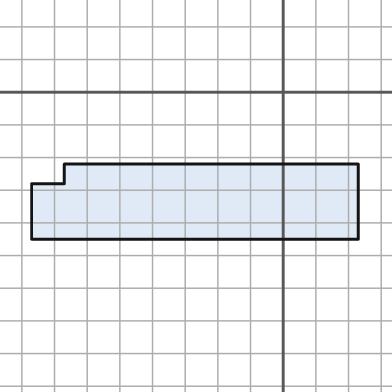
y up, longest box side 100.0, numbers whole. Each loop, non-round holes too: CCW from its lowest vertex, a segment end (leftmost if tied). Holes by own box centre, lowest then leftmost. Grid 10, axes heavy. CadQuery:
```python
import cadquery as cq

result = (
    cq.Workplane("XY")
    .moveTo(-77.0, -45.0)
    .lineTo(23.0, -45.0)
    .lineTo(23.0, -22.0)
    .lineTo(-67.0, -22.0)
    .lineTo(-67.0, -28.0)
    .lineTo(-77.0, -28.0)
    .close()
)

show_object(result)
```